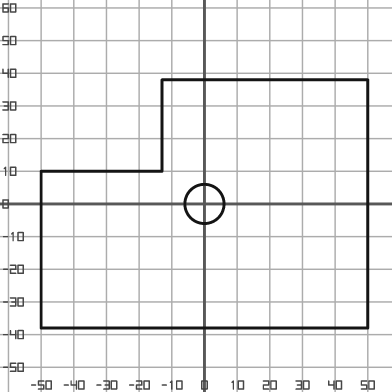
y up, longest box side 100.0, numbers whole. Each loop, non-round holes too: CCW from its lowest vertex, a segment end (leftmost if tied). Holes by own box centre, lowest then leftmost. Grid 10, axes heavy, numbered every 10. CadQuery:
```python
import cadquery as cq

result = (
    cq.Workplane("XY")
    .moveTo(-50.0, -38.0)
    .lineTo(50.0, -38.0)
    .lineTo(50.0, 38.0)
    .lineTo(-13.0, 38.0)
    .lineTo(-13.0, 10.0)
    .lineTo(-50.0, 10.0)
    .close()
    .moveTo(0.0, 0.0)
    .circle(6.0)
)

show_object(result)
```